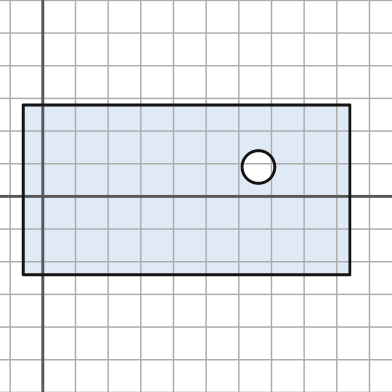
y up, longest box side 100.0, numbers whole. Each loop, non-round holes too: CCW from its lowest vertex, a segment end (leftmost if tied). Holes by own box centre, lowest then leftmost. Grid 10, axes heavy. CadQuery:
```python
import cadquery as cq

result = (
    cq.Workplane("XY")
    .moveTo(-6.0, -24.0)
    .lineTo(94.0, -24.0)
    .lineTo(94.0, 28.0)
    .lineTo(-6.0, 28.0)
    .close()
    .moveTo(66.0, 9.0)
    .circle(5.0)
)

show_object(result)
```